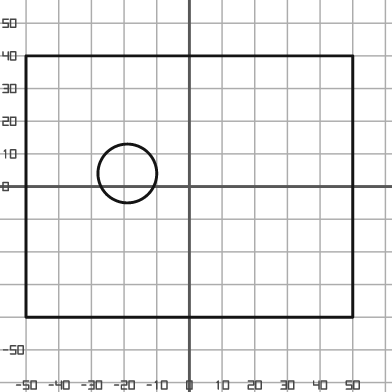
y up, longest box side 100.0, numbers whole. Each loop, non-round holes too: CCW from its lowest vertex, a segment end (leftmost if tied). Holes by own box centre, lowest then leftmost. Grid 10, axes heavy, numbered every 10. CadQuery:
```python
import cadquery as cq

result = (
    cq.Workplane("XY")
    .moveTo(-50.0, -40.0)
    .lineTo(50.0, -40.0)
    .lineTo(50.0, 40.0)
    .lineTo(-50.0, 40.0)
    .close()
    .moveTo(-19.0, 4.0)
    .circle(9.0)
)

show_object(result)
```